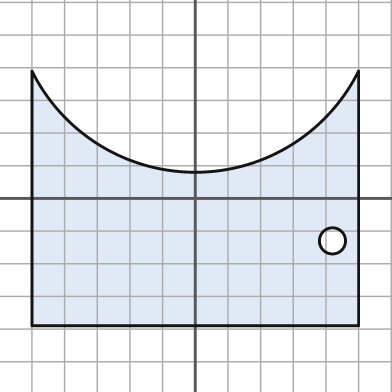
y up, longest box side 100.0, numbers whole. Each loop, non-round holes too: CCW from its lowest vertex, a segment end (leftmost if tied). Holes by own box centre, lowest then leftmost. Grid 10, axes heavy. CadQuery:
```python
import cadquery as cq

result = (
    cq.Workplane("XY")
    .moveTo(-50.0, -39.0)
    .lineTo(50.0, -39.0)
    .lineTo(50.0, 39.0)
    .threePointArc((0.0, 8.0), (-50.0, 39.0))
    .close()
    .moveTo(42.0, -13.0)
    .circle(4.0)
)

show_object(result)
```